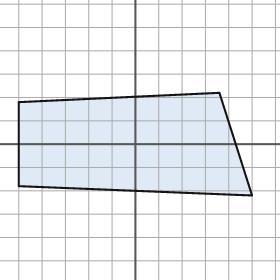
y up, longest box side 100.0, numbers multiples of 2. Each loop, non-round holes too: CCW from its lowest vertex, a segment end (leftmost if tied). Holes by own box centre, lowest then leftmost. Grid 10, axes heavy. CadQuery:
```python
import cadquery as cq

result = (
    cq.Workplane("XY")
    .moveTo(50.0, -22.0)
    .lineTo(36.0, 22.0)
    .lineTo(-50.0, 18.0)
    .lineTo(-50.0, -18.0)
    .close()
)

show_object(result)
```